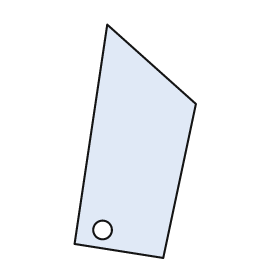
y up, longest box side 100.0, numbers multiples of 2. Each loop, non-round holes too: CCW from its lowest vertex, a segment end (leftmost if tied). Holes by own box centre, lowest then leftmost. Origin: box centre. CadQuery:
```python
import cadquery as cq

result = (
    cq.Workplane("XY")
    .moveTo(12.0, -50.0)
    .lineTo(26.0, 16.0)
    .lineTo(-12.0, 50.0)
    .lineTo(-26.0, -44.0)
    .close()
    .moveTo(-14.0, -38.0)
    .circle(4.0)
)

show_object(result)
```